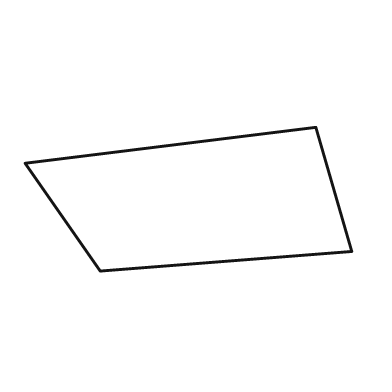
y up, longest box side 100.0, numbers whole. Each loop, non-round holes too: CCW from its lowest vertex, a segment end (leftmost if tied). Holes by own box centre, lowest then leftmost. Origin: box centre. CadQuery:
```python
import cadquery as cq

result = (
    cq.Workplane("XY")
    .moveTo(-27.0, -22.0)
    .lineTo(50.0, -16.0)
    .lineTo(39.0, 22.0)
    .lineTo(-50.0, 11.0)
    .close()
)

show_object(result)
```